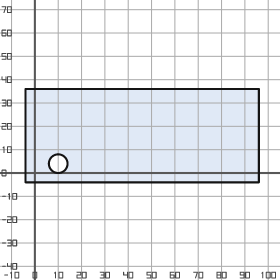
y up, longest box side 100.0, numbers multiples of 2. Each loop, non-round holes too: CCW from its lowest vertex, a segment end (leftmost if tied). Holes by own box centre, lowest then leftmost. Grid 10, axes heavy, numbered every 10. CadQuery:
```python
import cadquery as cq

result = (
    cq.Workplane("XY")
    .moveTo(-4.0, -4.0)
    .lineTo(96.0, -4.0)
    .lineTo(96.0, 36.0)
    .lineTo(-4.0, 36.0)
    .close()
    .moveTo(10.0, 4.0)
    .circle(4.0)
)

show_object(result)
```